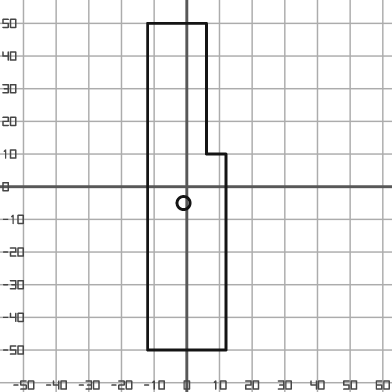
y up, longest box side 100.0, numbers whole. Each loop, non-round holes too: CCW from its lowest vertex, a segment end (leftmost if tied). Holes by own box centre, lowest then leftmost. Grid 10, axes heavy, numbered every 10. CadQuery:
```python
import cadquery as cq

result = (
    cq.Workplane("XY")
    .moveTo(-12.0, -50.0)
    .lineTo(12.0, -50.0)
    .lineTo(12.0, 10.0)
    .lineTo(6.0, 10.0)
    .lineTo(6.0, 50.0)
    .lineTo(-12.0, 50.0)
    .close()
    .moveTo(-1.0, -5.0)
    .circle(2.0)
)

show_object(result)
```